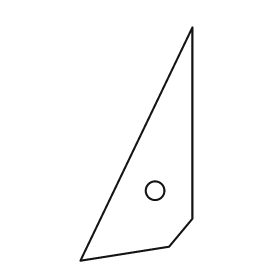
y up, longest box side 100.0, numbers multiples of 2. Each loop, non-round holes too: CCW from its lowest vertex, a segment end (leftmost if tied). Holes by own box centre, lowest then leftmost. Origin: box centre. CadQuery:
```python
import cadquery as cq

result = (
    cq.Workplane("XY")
    .moveTo(-24.0, -50.0)
    .lineTo(14.0, -44.0)
    .lineTo(24.0, -32.0)
    .lineTo(24.0, 50.0)
    .close()
    .moveTo(8.0, -20.0)
    .circle(4.0)
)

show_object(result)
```